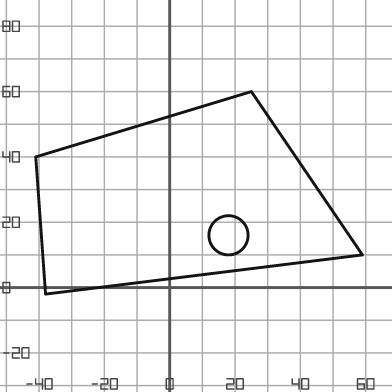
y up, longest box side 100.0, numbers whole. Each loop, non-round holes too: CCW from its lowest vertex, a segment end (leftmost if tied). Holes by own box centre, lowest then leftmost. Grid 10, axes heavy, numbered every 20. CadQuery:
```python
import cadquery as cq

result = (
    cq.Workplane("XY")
    .moveTo(-38.0, -2.0)
    .lineTo(59.0, 10.0)
    .lineTo(25.0, 60.0)
    .lineTo(-41.0, 40.0)
    .close()
    .moveTo(18.0, 16.0)
    .circle(6.0)
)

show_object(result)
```